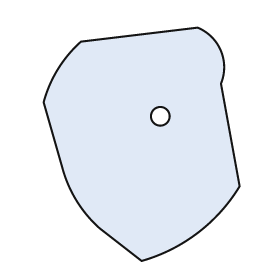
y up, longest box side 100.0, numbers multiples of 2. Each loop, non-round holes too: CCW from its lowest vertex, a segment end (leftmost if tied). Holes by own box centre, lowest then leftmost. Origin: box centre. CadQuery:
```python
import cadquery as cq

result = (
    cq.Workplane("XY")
    .moveTo(0.0, -50.0)
    .threePointArc((24.0, -38.0), (42.0, -18.0))
    .lineTo(34.0, 26.0)
    .threePointArc((34.0, 40.0), (24.0, 50.0))
    .lineTo(-26.0, 44.0)
    .threePointArc((-36.0, 32.0), (-42.0, 18.0))
    .lineTo(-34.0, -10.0)
    .threePointArc((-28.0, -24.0), (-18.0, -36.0))
    .close()
    .moveTo(8.0, 12.0)
    .circle(4.0)
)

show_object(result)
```